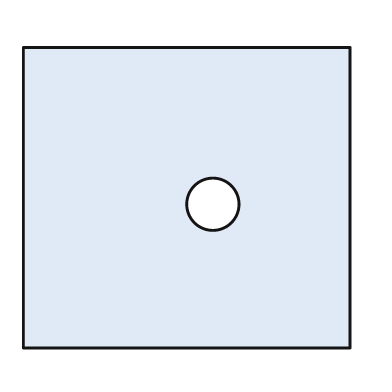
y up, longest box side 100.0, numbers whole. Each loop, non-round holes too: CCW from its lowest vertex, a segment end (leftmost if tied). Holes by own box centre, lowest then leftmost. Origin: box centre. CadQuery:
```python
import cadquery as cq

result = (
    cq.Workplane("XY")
    .moveTo(-50.0, -46.0)
    .lineTo(50.0, -46.0)
    .lineTo(50.0, 46.0)
    .lineTo(-50.0, 46.0)
    .close()
    .moveTo(8.0, -2.0)
    .circle(8.0)
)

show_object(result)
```